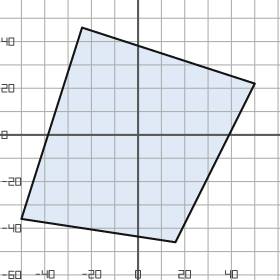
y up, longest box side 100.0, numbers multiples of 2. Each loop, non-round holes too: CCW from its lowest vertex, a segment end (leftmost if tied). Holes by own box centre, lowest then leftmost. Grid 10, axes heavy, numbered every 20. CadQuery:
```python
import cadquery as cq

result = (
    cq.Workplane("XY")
    .moveTo(16.0, -46.0)
    .lineTo(50.0, 22.0)
    .lineTo(-24.0, 46.0)
    .lineTo(-50.0, -36.0)
    .close()
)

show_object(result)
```